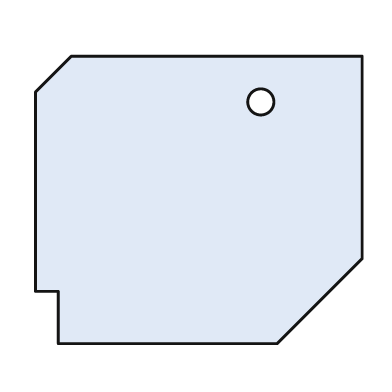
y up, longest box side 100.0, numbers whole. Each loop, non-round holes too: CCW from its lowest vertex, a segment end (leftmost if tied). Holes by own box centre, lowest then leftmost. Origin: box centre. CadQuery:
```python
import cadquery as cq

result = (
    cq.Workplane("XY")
    .moveTo(-43.0, -44.0)
    .lineTo(24.0, -44.0)
    .lineTo(50.0, -18.0)
    .lineTo(50.0, 44.0)
    .lineTo(-39.0, 44.0)
    .lineTo(-50.0, 33.0)
    .lineTo(-50.0, -28.0)
    .lineTo(-43.0, -28.0)
    .close()
    .moveTo(19.0, 30.0)
    .circle(4.0)
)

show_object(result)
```